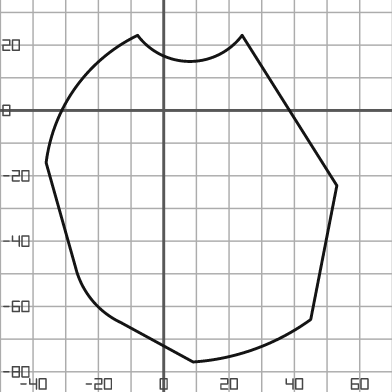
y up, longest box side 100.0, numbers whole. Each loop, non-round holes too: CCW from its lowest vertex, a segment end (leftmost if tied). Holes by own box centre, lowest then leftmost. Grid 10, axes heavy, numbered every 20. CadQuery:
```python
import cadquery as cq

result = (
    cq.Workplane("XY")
    .moveTo(9.0, -77.0)
    .threePointArc((28.0, -73.0), (45.0, -64.0))
    .lineTo(53.0, -23.0)
    .lineTo(24.0, 23.0)
    .threePointArc((8.0, 15.0), (-8.0, 23.0))
    .threePointArc((-27.0, 7.0), (-36.0, -16.0))
    .lineTo(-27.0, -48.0)
    .threePointArc((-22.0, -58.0), (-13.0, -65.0))
    .close()
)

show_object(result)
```